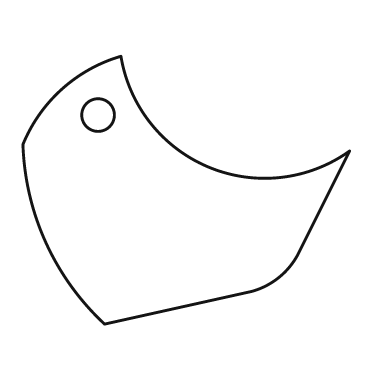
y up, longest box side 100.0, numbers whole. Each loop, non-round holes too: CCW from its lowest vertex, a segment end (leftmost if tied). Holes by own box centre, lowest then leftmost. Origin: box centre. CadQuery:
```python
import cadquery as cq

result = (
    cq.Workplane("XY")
    .moveTo(-25.0, -41.0)
    .lineTo(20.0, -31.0)
    .threePointArc((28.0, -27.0), (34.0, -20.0))
    .lineTo(50.0, 12.0)
    .threePointArc((7.0, 7.0), (-20.0, 41.0))
    .threePointArc((-38.0, 31.0), (-50.0, 14.0))
    .threePointArc((-43.0, -16.0), (-25.0, -41.0))
    .close()
    .moveTo(-27.0, 23.0)
    .circle(5.0)
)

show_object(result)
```